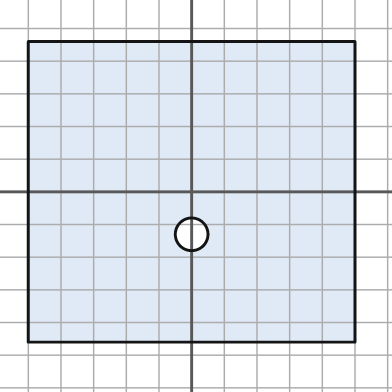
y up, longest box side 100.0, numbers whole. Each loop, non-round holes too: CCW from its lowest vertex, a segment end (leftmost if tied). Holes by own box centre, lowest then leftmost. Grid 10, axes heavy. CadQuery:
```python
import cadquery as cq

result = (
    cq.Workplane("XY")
    .moveTo(-50.0, -46.0)
    .lineTo(50.0, -46.0)
    .lineTo(50.0, 46.0)
    .lineTo(-50.0, 46.0)
    .close()
    .moveTo(0.0, -13.0)
    .circle(5.0)
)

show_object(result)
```